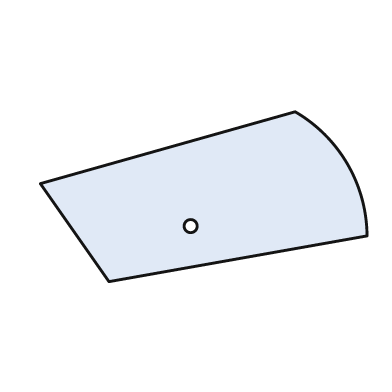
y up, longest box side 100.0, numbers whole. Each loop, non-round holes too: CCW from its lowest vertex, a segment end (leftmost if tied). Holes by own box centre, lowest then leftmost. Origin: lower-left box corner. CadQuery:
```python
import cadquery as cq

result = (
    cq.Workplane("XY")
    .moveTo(21.0, 0.0)
    .lineTo(100.0, 14.0)
    .threePointArc((94.0, 36.0), (78.0, 52.0))
    .lineTo(0.0, 30.0)
    .close()
    .moveTo(46.0, 17.0)
    .circle(2.0)
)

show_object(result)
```